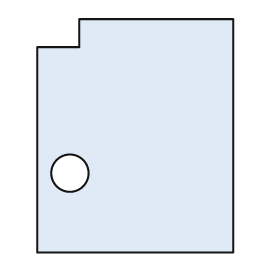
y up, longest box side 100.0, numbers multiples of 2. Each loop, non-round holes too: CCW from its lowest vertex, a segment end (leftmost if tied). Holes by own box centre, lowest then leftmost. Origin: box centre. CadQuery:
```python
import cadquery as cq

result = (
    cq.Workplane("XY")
    .moveTo(-42.0, -50.0)
    .lineTo(42.0, -50.0)
    .lineTo(42.0, 50.0)
    .lineTo(-24.0, 50.0)
    .lineTo(-24.0, 38.0)
    .lineTo(-42.0, 38.0)
    .close()
    .moveTo(-28.0, -16.0)
    .circle(8.0)
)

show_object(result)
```